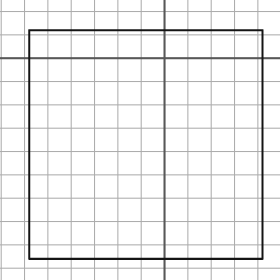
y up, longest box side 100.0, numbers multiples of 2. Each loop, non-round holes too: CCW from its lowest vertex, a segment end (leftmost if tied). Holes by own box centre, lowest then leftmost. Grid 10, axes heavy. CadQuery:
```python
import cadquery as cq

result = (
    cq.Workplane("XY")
    .moveTo(-58.0, -86.0)
    .lineTo(42.0, -86.0)
    .lineTo(42.0, 12.0)
    .lineTo(-58.0, 12.0)
    .close()
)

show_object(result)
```